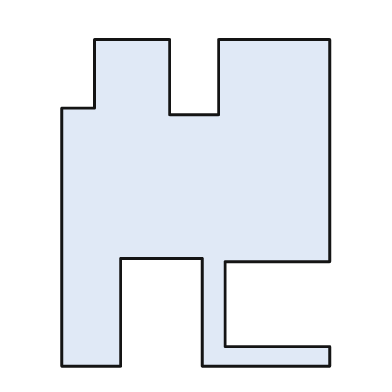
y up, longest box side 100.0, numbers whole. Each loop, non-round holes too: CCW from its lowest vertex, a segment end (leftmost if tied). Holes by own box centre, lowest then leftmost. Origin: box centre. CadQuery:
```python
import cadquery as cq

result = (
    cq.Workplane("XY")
    .moveTo(-41.0, -50.0)
    .lineTo(-23.0, -50.0)
    .lineTo(-23.0, -17.0)
    .lineTo(2.0, -17.0)
    .lineTo(2.0, -50.0)
    .lineTo(41.0, -50.0)
    .lineTo(41.0, -44.0)
    .lineTo(9.0, -44.0)
    .lineTo(9.0, -18.0)
    .lineTo(41.0, -18.0)
    .lineTo(41.0, 50.0)
    .lineTo(7.0, 50.0)
    .lineTo(7.0, 27.0)
    .lineTo(-8.0, 27.0)
    .lineTo(-8.0, 50.0)
    .lineTo(-31.0, 50.0)
    .lineTo(-31.0, 29.0)
    .lineTo(-41.0, 29.0)
    .close()
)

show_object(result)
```